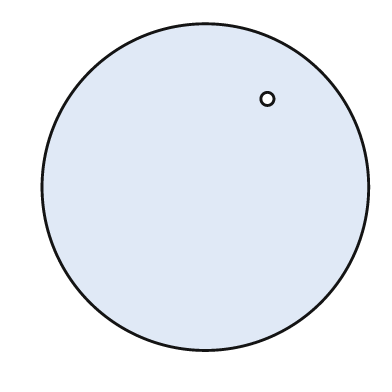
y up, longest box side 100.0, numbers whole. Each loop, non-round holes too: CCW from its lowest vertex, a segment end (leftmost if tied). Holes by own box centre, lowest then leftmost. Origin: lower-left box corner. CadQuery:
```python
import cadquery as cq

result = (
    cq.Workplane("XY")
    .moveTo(50.0, 50.0)
    .circle(50.0)
    .moveTo(69.0, 77.0)
    .circle(2.0)
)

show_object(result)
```